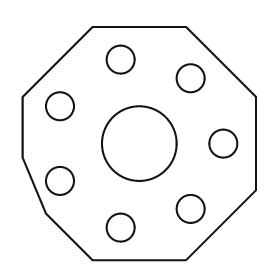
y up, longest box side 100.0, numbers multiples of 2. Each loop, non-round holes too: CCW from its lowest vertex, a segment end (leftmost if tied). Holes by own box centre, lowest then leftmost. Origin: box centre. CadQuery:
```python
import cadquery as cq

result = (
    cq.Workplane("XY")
    .moveTo(-20.0, -50.0)
    .lineTo(20.0, -50.0)
    .lineTo(50.0, -20.0)
    .lineTo(50.0, 20.0)
    .lineTo(20.0, 50.0)
    .lineTo(-20.0, 50.0)
    .lineTo(-50.0, 20.0)
    .lineTo(-50.0, -6.0)
    .lineTo(-40.0, -30.0)
    .close()
    .moveTo(-8.0, -36.0)
    .circle(6.0)
    .moveTo(22.0, -28.0)
    .circle(6.0)
    .moveTo(-34.0, -16.0)
    .circle(6.0)
    .moveTo(0.0, 0.0)
    .circle(16.0)
    .moveTo(36.0, 0.0)
    .circle(6.0)
    .moveTo(-34.0, 16.0)
    .circle(6.0)
    .moveTo(22.0, 28.0)
    .circle(6.0)
    .moveTo(-8.0, 36.0)
    .circle(6.0)
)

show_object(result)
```